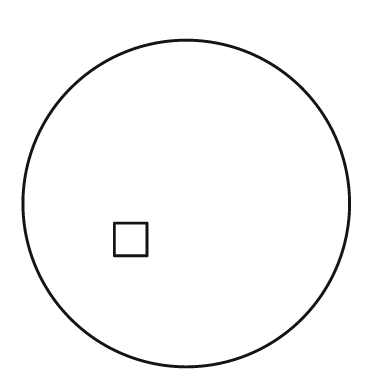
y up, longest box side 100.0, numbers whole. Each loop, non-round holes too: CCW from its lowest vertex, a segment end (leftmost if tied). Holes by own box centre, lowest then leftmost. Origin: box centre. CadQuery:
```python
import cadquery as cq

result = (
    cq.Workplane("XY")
    .moveTo(0.0, 0.0)
    .circle(50.0)
    .moveTo(-22.0, -16.0)
    .lineTo(-12.0, -16.0)
    .lineTo(-12.0, -6.0)
    .lineTo(-22.0, -6.0)
    .close()
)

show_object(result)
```